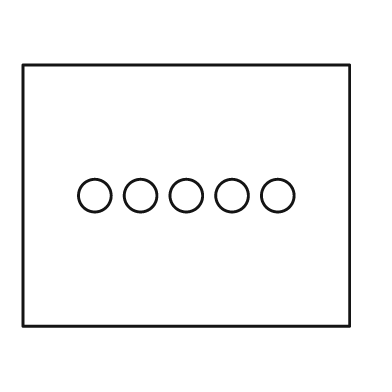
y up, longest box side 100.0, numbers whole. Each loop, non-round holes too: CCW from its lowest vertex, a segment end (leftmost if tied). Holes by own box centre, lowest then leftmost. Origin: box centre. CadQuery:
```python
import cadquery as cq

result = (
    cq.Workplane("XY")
    .moveTo(-50.0, -40.0)
    .lineTo(50.0, -40.0)
    .lineTo(50.0, 40.0)
    .lineTo(-50.0, 40.0)
    .close()
    .moveTo(-28.0, 0.0)
    .circle(5.0)
    .moveTo(-14.0, 0.0)
    .circle(5.0)
    .moveTo(0.0, 0.0)
    .circle(5.0)
    .moveTo(14.0, 0.0)
    .circle(5.0)
    .moveTo(28.0, 0.0)
    .circle(5.0)
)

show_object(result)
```